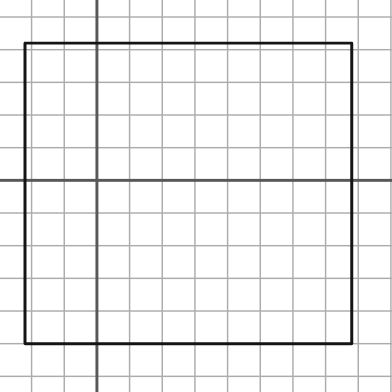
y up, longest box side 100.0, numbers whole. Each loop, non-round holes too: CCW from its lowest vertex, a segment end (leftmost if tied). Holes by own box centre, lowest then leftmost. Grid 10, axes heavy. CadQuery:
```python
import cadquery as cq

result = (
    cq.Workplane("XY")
    .moveTo(-22.0, -50.0)
    .lineTo(78.0, -50.0)
    .lineTo(78.0, 42.0)
    .lineTo(-22.0, 42.0)
    .close()
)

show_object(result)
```